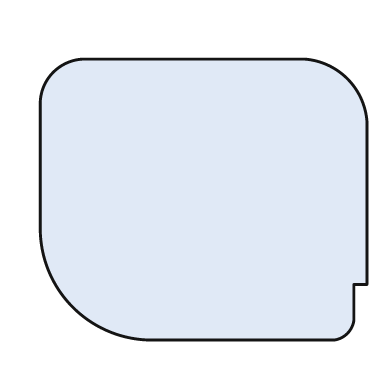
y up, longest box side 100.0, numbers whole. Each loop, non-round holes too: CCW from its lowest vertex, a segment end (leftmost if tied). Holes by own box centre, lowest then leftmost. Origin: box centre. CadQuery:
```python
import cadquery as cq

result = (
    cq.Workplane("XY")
    .moveTo(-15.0, -43.0)
    .lineTo(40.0, -43.0)
    .threePointArc((44.0, -41.0), (46.0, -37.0))
    .lineTo(46.0, -26.0)
    .lineTo(50.0, -26.0)
    .lineTo(50.0, 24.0)
    .threePointArc((44.0, 37.0), (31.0, 43.0))
    .lineTo(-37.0, 43.0)
    .threePointArc((-46.0, 39.0), (-50.0, 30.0))
    .lineTo(-50.0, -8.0)
    .threePointArc((-40.0, -33.0), (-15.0, -43.0))
    .close()
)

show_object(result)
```